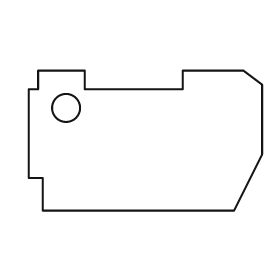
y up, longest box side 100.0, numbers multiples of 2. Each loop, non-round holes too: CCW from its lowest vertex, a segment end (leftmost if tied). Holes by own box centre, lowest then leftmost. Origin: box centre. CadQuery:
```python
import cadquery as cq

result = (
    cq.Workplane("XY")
    .moveTo(-44.0, -30.0)
    .lineTo(38.0, -30.0)
    .lineTo(50.0, -6.0)
    .lineTo(50.0, 24.0)
    .lineTo(42.0, 30.0)
    .lineTo(16.0, 30.0)
    .lineTo(16.0, 22.0)
    .lineTo(-26.0, 22.0)
    .lineTo(-26.0, 30.0)
    .lineTo(-46.0, 30.0)
    .lineTo(-46.0, 22.0)
    .lineTo(-50.0, 22.0)
    .lineTo(-50.0, -16.0)
    .lineTo(-44.0, -16.0)
    .close()
    .moveTo(-34.0, 14.0)
    .circle(6.0)
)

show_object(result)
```